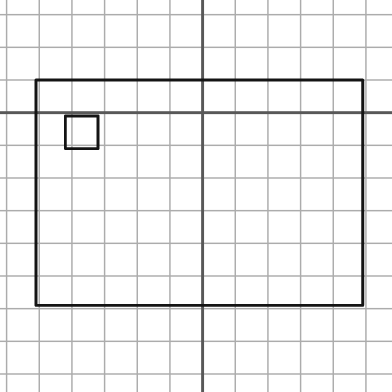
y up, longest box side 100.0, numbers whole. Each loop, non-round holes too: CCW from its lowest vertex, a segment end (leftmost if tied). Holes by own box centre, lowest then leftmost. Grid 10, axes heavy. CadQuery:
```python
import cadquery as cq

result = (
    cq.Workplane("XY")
    .moveTo(-51.0, -59.0)
    .lineTo(49.0, -59.0)
    .lineTo(49.0, 10.0)
    .lineTo(-51.0, 10.0)
    .close()
    .moveTo(-42.0, -11.0)
    .lineTo(-32.0, -11.0)
    .lineTo(-32.0, -1.0)
    .lineTo(-42.0, -1.0)
    .close()
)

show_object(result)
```